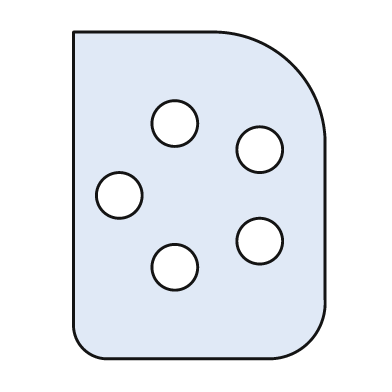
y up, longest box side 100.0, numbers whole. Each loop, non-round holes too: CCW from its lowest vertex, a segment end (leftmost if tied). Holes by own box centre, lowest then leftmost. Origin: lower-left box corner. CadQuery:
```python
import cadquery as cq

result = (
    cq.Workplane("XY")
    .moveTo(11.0, 0.0)
    .lineTo(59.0, 0.0)
    .threePointArc((72.0, 5.0), (77.0, 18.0))
    .lineTo(77.0, 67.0)
    .threePointArc((67.0, 90.0), (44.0, 100.0))
    .lineTo(0.0, 100.0)
    .lineTo(0.0, 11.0)
    .threePointArc((3.0, 3.0), (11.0, 0.0))
    .close()
    .moveTo(31.0, 28.0)
    .circle(7.0)
    .moveTo(57.0, 36.0)
    .circle(7.0)
    .moveTo(14.0, 50.0)
    .circle(7.0)
    .moveTo(57.0, 64.0)
    .circle(7.0)
    .moveTo(31.0, 72.0)
    .circle(7.0)
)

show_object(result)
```